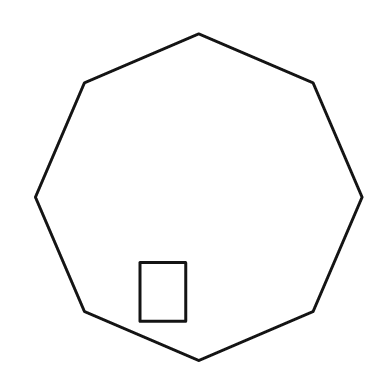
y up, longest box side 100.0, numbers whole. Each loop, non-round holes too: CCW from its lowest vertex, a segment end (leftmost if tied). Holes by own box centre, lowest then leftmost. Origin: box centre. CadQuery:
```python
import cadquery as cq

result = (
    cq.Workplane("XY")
    .moveTo(0.0, -50.0)
    .lineTo(35.0, -35.0)
    .lineTo(50.0, 0.0)
    .lineTo(35.0, 35.0)
    .lineTo(0.0, 50.0)
    .lineTo(-35.0, 35.0)
    .lineTo(-50.0, 0.0)
    .lineTo(-35.0, -35.0)
    .close()
    .moveTo(-18.0, -38.0)
    .lineTo(-4.0, -38.0)
    .lineTo(-4.0, -20.0)
    .lineTo(-18.0, -20.0)
    .close()
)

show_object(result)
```